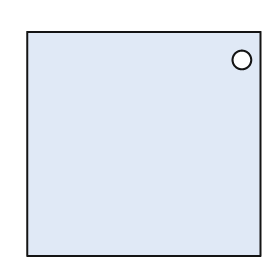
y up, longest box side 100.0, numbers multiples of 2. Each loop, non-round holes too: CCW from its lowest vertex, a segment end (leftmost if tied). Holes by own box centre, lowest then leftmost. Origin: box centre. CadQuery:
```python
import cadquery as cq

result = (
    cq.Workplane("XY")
    .moveTo(-50.0, -48.0)
    .lineTo(50.0, -48.0)
    .lineTo(50.0, 48.0)
    .lineTo(-50.0, 48.0)
    .close()
    .moveTo(42.0, 36.0)
    .circle(4.0)
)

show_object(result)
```